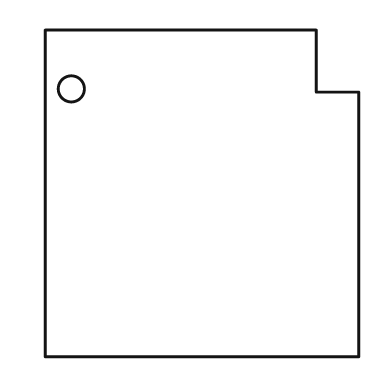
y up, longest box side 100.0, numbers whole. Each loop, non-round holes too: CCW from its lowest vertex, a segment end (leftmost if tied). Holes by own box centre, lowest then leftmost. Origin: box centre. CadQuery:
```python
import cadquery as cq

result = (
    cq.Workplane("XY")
    .moveTo(-48.0, -50.0)
    .lineTo(48.0, -50.0)
    .lineTo(48.0, 31.0)
    .lineTo(35.0, 31.0)
    .lineTo(35.0, 50.0)
    .lineTo(-48.0, 50.0)
    .close()
    .moveTo(-40.0, 32.0)
    .circle(4.0)
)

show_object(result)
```